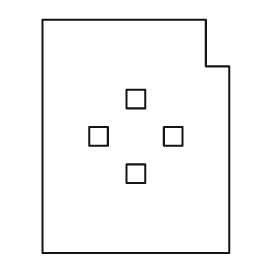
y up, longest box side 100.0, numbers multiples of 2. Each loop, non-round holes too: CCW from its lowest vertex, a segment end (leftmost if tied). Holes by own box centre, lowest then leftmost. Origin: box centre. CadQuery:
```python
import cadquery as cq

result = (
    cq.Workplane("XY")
    .moveTo(-40.0, -50.0)
    .lineTo(40.0, -50.0)
    .lineTo(40.0, 30.0)
    .lineTo(30.0, 30.0)
    .lineTo(30.0, 50.0)
    .lineTo(-40.0, 50.0)
    .close()
    .moveTo(-4.0, -20.0)
    .lineTo(4.0, -20.0)
    .lineTo(4.0, -12.0)
    .lineTo(-4.0, -12.0)
    .close()
    .moveTo(-20.0, -4.0)
    .lineTo(-12.0, -4.0)
    .lineTo(-12.0, 4.0)
    .lineTo(-20.0, 4.0)
    .close()
    .moveTo(12.0, -4.0)
    .lineTo(20.0, -4.0)
    .lineTo(20.0, 4.0)
    .lineTo(12.0, 4.0)
    .close()
    .moveTo(-4.0, 12.0)
    .lineTo(4.0, 12.0)
    .lineTo(4.0, 20.0)
    .lineTo(-4.0, 20.0)
    .close()
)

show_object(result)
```